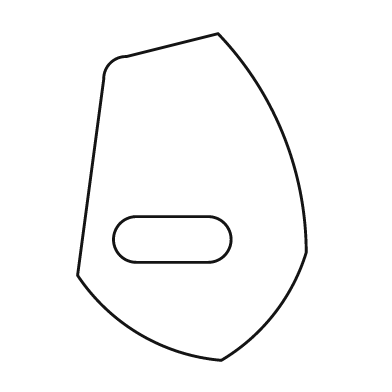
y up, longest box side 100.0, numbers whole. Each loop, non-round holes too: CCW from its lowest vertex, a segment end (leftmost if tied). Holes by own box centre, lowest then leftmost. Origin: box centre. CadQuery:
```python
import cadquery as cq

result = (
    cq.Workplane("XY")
    .moveTo(9.0, -50.0)
    .threePointArc((25.0, -36.0), (35.0, -17.0))
    .threePointArc((28.0, 19.0), (8.0, 50.0))
    .lineTo(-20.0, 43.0)
    .threePointArc((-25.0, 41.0), (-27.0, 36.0))
    .lineTo(-35.0, -24.0)
    .threePointArc((-16.0, -42.0), (9.0, -50.0))
    .close()
    .moveTo(-17.0, -20.0)
    .lineTo(5.0, -20.0)
    .threePointArc((12.0, -13.0), (5.0, -6.0))
    .lineTo(-17.0, -6.0)
    .threePointArc((-24.0, -13.0), (-17.0, -20.0))
    .close()
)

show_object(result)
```